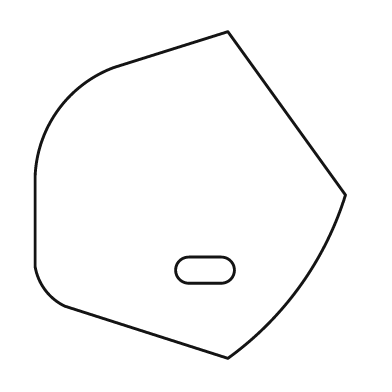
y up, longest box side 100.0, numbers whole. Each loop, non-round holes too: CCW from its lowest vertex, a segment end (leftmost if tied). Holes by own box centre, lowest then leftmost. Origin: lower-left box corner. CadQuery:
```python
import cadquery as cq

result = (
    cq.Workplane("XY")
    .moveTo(59.0, 0.0)
    .threePointArc((81.0, 22.0), (95.0, 50.0))
    .lineTo(59.0, 100.0)
    .lineTo(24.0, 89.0)
    .threePointArc((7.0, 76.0), (0.0, 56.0))
    .lineTo(0.0, 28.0)
    .threePointArc((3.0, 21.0), (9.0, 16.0))
    .close()
    .moveTo(47.0, 23.0)
    .lineTo(57.0, 23.0)
    .threePointArc((61.0, 27.0), (57.0, 31.0))
    .lineTo(47.0, 31.0)
    .threePointArc((43.0, 27.0), (47.0, 23.0))
    .close()
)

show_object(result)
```